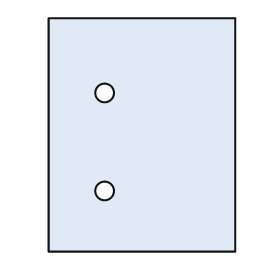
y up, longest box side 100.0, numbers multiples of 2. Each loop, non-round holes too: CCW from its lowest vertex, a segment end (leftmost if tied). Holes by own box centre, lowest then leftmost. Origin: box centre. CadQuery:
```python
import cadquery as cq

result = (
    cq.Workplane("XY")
    .moveTo(-40.0, -50.0)
    .lineTo(40.0, -50.0)
    .lineTo(40.0, 50.0)
    .lineTo(-40.0, 50.0)
    .close()
    .moveTo(-16.0, -24.0)
    .circle(4.0)
    .moveTo(-16.0, 18.0)
    .circle(4.0)
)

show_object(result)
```